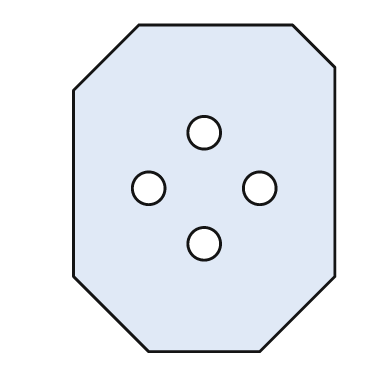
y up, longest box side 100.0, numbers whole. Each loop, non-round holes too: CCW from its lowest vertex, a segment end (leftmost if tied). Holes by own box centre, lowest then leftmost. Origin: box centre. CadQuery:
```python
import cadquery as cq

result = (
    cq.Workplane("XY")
    .moveTo(-17.0, -50.0)
    .lineTo(17.0, -50.0)
    .lineTo(40.0, -27.0)
    .lineTo(40.0, 37.0)
    .lineTo(27.0, 50.0)
    .lineTo(-20.0, 50.0)
    .lineTo(-40.0, 30.0)
    .lineTo(-40.0, -27.0)
    .close()
    .moveTo(0.0, -17.0)
    .circle(5.0)
    .moveTo(-17.0, 0.0)
    .circle(5.0)
    .moveTo(17.0, 0.0)
    .circle(5.0)
    .moveTo(0.0, 17.0)
    .circle(5.0)
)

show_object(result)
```